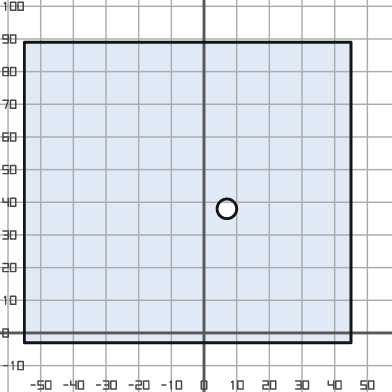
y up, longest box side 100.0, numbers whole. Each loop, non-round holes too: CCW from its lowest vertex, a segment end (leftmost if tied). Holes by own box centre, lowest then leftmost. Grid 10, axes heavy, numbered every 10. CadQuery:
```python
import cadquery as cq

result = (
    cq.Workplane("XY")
    .moveTo(-55.0, -3.0)
    .lineTo(45.0, -3.0)
    .lineTo(45.0, 89.0)
    .lineTo(-55.0, 89.0)
    .close()
    .moveTo(7.0, 38.0)
    .circle(3.0)
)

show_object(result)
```